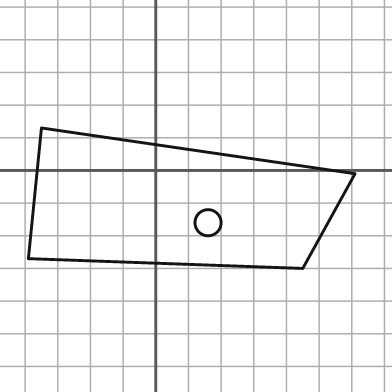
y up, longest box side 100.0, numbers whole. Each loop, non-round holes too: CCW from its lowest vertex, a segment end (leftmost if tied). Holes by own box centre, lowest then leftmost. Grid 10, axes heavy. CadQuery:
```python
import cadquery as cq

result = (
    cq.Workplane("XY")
    .moveTo(45.0, -30.0)
    .lineTo(61.0, -1.0)
    .lineTo(-35.0, 13.0)
    .lineTo(-39.0, -27.0)
    .close()
    .moveTo(16.0, -16.0)
    .circle(4.0)
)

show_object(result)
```